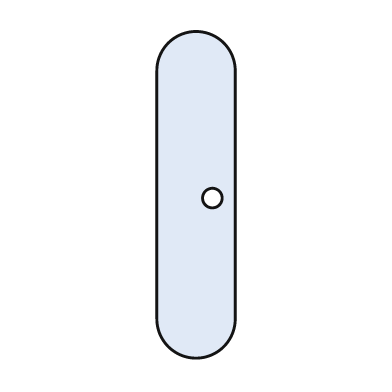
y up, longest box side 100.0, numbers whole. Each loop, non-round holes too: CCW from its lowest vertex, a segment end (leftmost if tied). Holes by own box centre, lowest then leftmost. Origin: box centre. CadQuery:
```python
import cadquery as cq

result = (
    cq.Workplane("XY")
    .moveTo(-12.0, -38.0)
    .threePointArc((0.0, -50.0), (12.0, -38.0))
    .lineTo(12.0, 38.0)
    .threePointArc((0.0, 50.0), (-12.0, 38.0))
    .close()
    .moveTo(5.0, -1.0)
    .circle(3.0)
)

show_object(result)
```